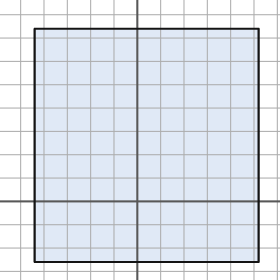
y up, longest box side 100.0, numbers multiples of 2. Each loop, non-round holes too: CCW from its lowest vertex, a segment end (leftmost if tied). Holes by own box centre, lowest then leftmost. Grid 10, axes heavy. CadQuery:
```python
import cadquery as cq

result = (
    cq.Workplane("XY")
    .moveTo(-44.0, -26.0)
    .lineTo(52.0, -26.0)
    .lineTo(52.0, 74.0)
    .lineTo(-44.0, 74.0)
    .close()
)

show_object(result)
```